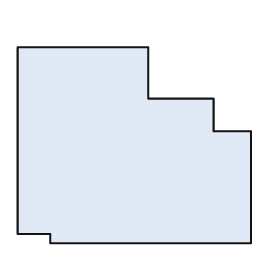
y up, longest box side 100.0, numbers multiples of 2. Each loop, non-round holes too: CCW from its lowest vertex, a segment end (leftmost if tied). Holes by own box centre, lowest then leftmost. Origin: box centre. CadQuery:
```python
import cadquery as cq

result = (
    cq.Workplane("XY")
    .moveTo(-36.0, -42.0)
    .lineTo(50.0, -42.0)
    .lineTo(50.0, 6.0)
    .lineTo(34.0, 6.0)
    .lineTo(34.0, 20.0)
    .lineTo(6.0, 20.0)
    .lineTo(6.0, 42.0)
    .lineTo(-50.0, 42.0)
    .lineTo(-50.0, -38.0)
    .lineTo(-36.0, -38.0)
    .close()
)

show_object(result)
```